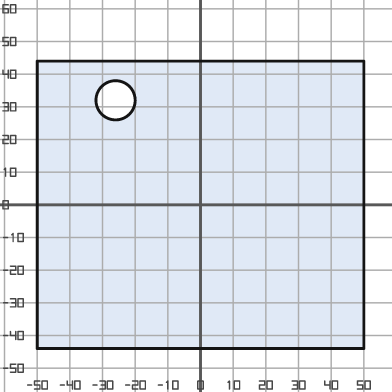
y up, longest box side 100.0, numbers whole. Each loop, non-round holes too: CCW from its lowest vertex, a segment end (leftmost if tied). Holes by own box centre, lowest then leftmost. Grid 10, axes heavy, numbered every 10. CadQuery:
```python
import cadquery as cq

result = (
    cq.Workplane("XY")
    .moveTo(-50.0, -44.0)
    .lineTo(50.0, -44.0)
    .lineTo(50.0, 44.0)
    .lineTo(-50.0, 44.0)
    .close()
    .moveTo(-26.0, 32.0)
    .circle(6.0)
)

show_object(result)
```